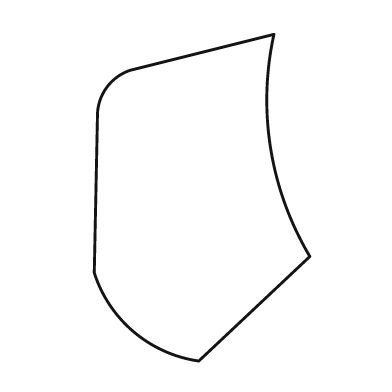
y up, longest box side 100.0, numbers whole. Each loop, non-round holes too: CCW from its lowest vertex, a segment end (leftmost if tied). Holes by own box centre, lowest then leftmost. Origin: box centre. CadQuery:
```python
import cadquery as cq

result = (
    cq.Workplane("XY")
    .moveTo(-1.0, -50.0)
    .lineTo(33.0, -18.0)
    .threePointArc((21.0, 15.0), (22.0, 50.0))
    .lineTo(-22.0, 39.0)
    .threePointArc((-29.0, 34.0), (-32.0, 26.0))
    .lineTo(-33.0, -23.0)
    .threePointArc((-21.0, -41.0), (-1.0, -50.0))
    .close()
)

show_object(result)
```